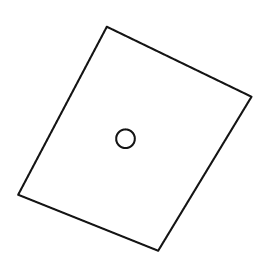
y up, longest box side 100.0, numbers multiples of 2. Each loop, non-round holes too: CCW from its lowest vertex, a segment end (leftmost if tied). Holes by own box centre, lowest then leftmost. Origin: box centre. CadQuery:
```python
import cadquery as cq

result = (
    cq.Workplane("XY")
    .moveTo(10.0, -48.0)
    .lineTo(50.0, 18.0)
    .lineTo(-12.0, 48.0)
    .lineTo(-50.0, -24.0)
    .close()
    .moveTo(-4.0, 0.0)
    .circle(4.0)
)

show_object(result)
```